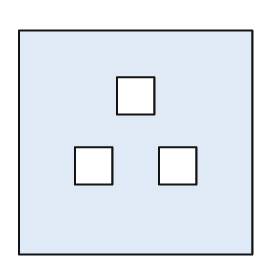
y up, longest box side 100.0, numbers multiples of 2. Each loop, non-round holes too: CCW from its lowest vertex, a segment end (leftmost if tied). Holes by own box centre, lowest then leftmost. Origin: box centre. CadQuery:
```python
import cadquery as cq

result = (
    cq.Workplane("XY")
    .moveTo(-50.0, -48.0)
    .lineTo(50.0, -48.0)
    .lineTo(50.0, 48.0)
    .lineTo(-50.0, 48.0)
    .close()
    .moveTo(-26.0, -18.0)
    .lineTo(-10.0, -18.0)
    .lineTo(-10.0, -2.0)
    .lineTo(-26.0, -2.0)
    .close()
    .moveTo(10.0, -18.0)
    .lineTo(26.0, -18.0)
    .lineTo(26.0, -2.0)
    .lineTo(10.0, -2.0)
    .close()
    .moveTo(-8.0, 12.0)
    .lineTo(8.0, 12.0)
    .lineTo(8.0, 28.0)
    .lineTo(-8.0, 28.0)
    .close()
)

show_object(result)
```